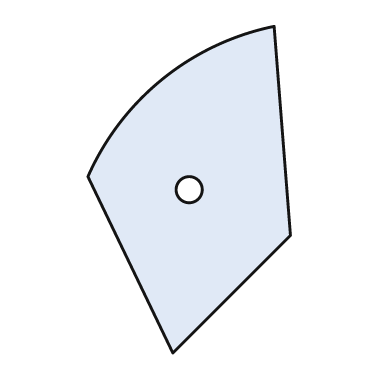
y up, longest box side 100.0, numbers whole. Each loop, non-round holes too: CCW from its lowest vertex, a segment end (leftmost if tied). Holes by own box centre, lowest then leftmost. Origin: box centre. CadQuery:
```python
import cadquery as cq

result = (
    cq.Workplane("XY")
    .moveTo(-5.0, -50.0)
    .lineTo(31.0, -14.0)
    .lineTo(26.0, 50.0)
    .threePointArc((-8.0, 34.0), (-31.0, 4.0))
    .close()
    .moveTo(0.0, 0.0)
    .circle(4.0)
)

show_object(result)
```